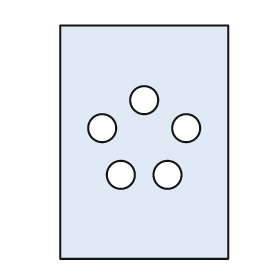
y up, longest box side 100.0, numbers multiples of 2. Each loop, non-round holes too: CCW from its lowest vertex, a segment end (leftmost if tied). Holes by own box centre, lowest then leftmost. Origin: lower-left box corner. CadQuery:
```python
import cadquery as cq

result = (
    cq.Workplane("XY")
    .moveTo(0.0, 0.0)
    .lineTo(72.0, 0.0)
    .lineTo(72.0, 100.0)
    .lineTo(0.0, 100.0)
    .close()
    .moveTo(26.0, 36.0)
    .circle(6.0)
    .moveTo(46.0, 36.0)
    .circle(6.0)
    .moveTo(18.0, 56.0)
    .circle(6.0)
    .moveTo(54.0, 56.0)
    .circle(6.0)
    .moveTo(36.0, 68.0)
    .circle(6.0)
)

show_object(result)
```